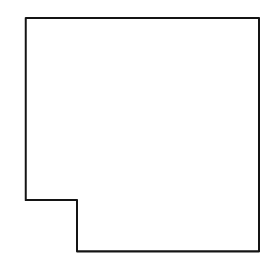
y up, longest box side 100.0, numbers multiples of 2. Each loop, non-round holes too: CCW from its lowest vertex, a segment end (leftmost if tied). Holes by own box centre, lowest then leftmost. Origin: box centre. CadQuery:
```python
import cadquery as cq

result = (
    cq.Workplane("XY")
    .moveTo(-28.0, -50.0)
    .lineTo(50.0, -50.0)
    .lineTo(50.0, 50.0)
    .lineTo(-50.0, 50.0)
    .lineTo(-50.0, -28.0)
    .lineTo(-28.0, -28.0)
    .close()
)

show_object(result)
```